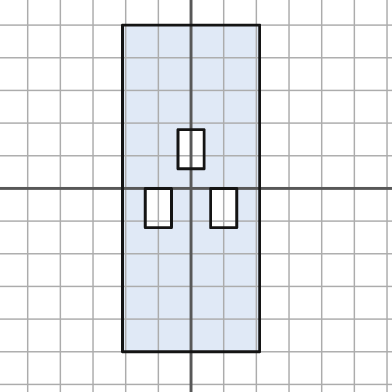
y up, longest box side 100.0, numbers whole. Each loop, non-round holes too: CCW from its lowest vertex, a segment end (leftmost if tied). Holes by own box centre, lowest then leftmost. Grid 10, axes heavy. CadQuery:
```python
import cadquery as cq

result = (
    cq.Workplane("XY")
    .moveTo(-21.0, -50.0)
    .lineTo(21.0, -50.0)
    .lineTo(21.0, 50.0)
    .lineTo(-21.0, 50.0)
    .close()
    .moveTo(-14.0, -12.0)
    .lineTo(-6.0, -12.0)
    .lineTo(-6.0, 0.0)
    .lineTo(-14.0, 0.0)
    .close()
    .moveTo(6.0, -12.0)
    .lineTo(14.0, -12.0)
    .lineTo(14.0, 0.0)
    .lineTo(6.0, 0.0)
    .close()
    .moveTo(-4.0, 6.0)
    .lineTo(4.0, 6.0)
    .lineTo(4.0, 18.0)
    .lineTo(-4.0, 18.0)
    .close()
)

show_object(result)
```